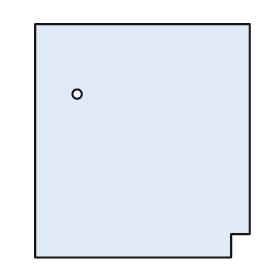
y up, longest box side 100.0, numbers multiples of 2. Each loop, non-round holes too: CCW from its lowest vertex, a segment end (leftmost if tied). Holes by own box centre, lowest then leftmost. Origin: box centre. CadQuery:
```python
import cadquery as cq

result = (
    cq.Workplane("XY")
    .moveTo(-46.0, -50.0)
    .lineTo(38.0, -50.0)
    .lineTo(38.0, -40.0)
    .lineTo(46.0, -40.0)
    .lineTo(46.0, 50.0)
    .lineTo(-46.0, 50.0)
    .close()
    .moveTo(-28.0, 20.0)
    .circle(2.0)
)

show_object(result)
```